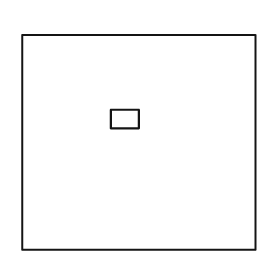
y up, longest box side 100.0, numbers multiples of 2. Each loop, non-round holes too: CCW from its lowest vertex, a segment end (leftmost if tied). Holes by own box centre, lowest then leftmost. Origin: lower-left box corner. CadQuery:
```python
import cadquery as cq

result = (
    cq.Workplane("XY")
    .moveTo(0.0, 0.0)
    .lineTo(100.0, 0.0)
    .lineTo(100.0, 92.0)
    .lineTo(0.0, 92.0)
    .close()
    .moveTo(38.0, 52.0)
    .lineTo(50.0, 52.0)
    .lineTo(50.0, 60.0)
    .lineTo(38.0, 60.0)
    .close()
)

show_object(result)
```